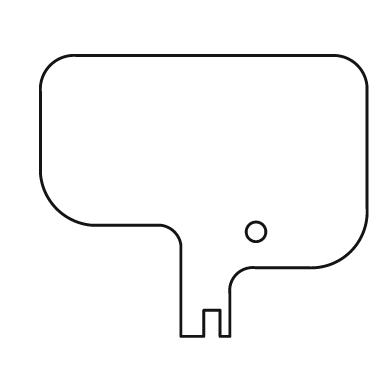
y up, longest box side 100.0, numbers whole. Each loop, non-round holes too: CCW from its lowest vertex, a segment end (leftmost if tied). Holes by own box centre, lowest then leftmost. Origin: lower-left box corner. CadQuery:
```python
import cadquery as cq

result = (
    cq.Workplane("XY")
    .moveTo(43.0, 0.0)
    .lineTo(50.0, 0.0)
    .lineTo(50.0, 8.0)
    .lineTo(55.0, 8.0)
    .lineTo(55.0, 0.0)
    .lineTo(58.0, 0.0)
    .lineTo(58.0, 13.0)
    .threePointArc((60.0, 19.0), (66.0, 21.0))
    .lineTo(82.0, 21.0)
    .threePointArc((95.0, 26.0), (100.0, 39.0))
    .lineTo(100.0, 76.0)
    .threePointArc((97.0, 83.0), (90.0, 86.0))
    .lineTo(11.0, 86.0)
    .threePointArc((3.0, 83.0), (0.0, 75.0))
    .lineTo(0.0, 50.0)
    .threePointArc((5.0, 39.0), (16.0, 34.0))
    .lineTo(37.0, 34.0)
    .threePointArc((41.0, 32.0), (43.0, 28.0))
    .close()
    .moveTo(66.0, 32.0)
    .circle(3.0)
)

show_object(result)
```